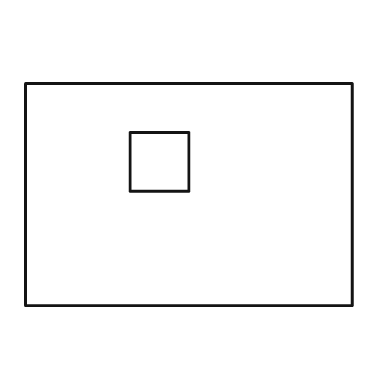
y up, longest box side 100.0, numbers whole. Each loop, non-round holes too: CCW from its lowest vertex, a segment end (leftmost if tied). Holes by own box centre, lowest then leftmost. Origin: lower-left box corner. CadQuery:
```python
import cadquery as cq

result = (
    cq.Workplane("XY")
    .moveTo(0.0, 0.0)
    .lineTo(100.0, 0.0)
    .lineTo(100.0, 68.0)
    .lineTo(0.0, 68.0)
    .close()
    .moveTo(32.0, 35.0)
    .lineTo(50.0, 35.0)
    .lineTo(50.0, 53.0)
    .lineTo(32.0, 53.0)
    .close()
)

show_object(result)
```